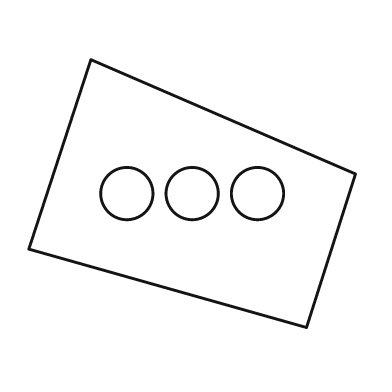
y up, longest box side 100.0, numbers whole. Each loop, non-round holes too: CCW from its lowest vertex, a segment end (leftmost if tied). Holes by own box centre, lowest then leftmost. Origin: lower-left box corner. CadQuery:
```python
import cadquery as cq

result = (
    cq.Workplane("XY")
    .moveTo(85.0, 0.0)
    .lineTo(100.0, 47.0)
    .lineTo(19.0, 82.0)
    .lineTo(0.0, 24.0)
    .close()
    .moveTo(30.0, 41.0)
    .circle(8.0)
    .moveTo(50.0, 41.0)
    .circle(8.0)
    .moveTo(70.0, 41.0)
    .circle(8.0)
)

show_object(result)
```